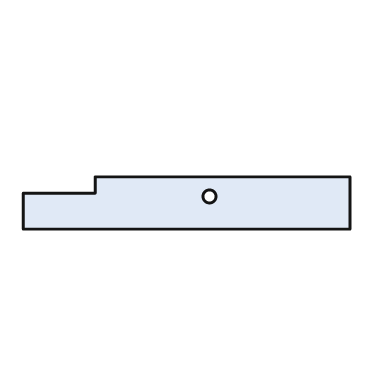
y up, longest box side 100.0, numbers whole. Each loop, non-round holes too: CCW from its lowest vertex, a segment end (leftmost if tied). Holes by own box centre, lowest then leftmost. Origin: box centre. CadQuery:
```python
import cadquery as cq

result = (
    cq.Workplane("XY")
    .moveTo(-50.0, -8.0)
    .lineTo(50.0, -8.0)
    .lineTo(50.0, 8.0)
    .lineTo(-28.0, 8.0)
    .lineTo(-28.0, 3.0)
    .lineTo(-50.0, 3.0)
    .close()
    .moveTo(7.0, 2.0)
    .circle(2.0)
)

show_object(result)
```